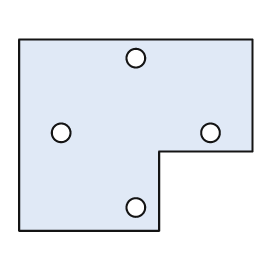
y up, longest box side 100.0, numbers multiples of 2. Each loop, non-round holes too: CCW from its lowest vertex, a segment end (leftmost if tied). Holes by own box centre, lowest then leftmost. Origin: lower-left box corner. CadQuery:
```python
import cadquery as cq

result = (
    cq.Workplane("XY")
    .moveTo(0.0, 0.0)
    .lineTo(60.0, 0.0)
    .lineTo(60.0, 34.0)
    .lineTo(100.0, 34.0)
    .lineTo(100.0, 82.0)
    .lineTo(0.0, 82.0)
    .close()
    .moveTo(50.0, 10.0)
    .circle(4.0)
    .moveTo(18.0, 42.0)
    .circle(4.0)
    .moveTo(82.0, 42.0)
    .circle(4.0)
    .moveTo(50.0, 74.0)
    .circle(4.0)
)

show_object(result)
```